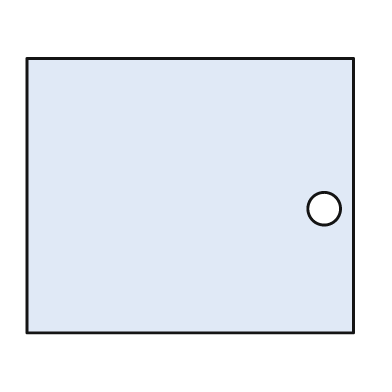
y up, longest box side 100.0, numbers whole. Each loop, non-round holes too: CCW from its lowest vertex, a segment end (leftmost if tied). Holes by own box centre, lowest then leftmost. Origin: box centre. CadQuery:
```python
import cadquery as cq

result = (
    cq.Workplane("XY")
    .moveTo(-50.0, -42.0)
    .lineTo(50.0, -42.0)
    .lineTo(50.0, 42.0)
    .lineTo(-50.0, 42.0)
    .close()
    .moveTo(41.0, -4.0)
    .circle(5.0)
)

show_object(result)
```